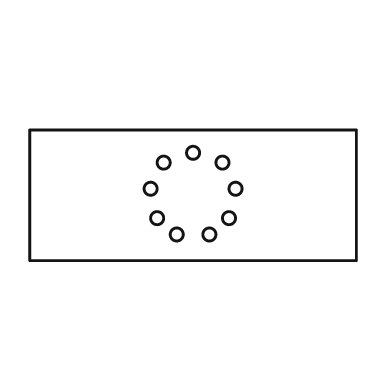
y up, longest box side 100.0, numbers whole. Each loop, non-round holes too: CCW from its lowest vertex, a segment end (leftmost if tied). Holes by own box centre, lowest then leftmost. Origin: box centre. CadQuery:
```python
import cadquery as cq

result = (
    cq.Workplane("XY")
    .moveTo(-50.0, -20.0)
    .lineTo(50.0, -20.0)
    .lineTo(50.0, 20.0)
    .lineTo(-50.0, 20.0)
    .close()
    .moveTo(-5.0, -12.0)
    .circle(2.0)
    .moveTo(5.0, -12.0)
    .circle(2.0)
    .moveTo(-11.0, -7.0)
    .circle(2.0)
    .moveTo(11.0, -7.0)
    .circle(2.0)
    .moveTo(-13.0, 2.0)
    .circle(2.0)
    .moveTo(13.0, 2.0)
    .circle(2.0)
    .moveTo(-9.0, 10.0)
    .circle(2.0)
    .moveTo(9.0, 10.0)
    .circle(2.0)
    .moveTo(0.0, 13.0)
    .circle(2.0)
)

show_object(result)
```